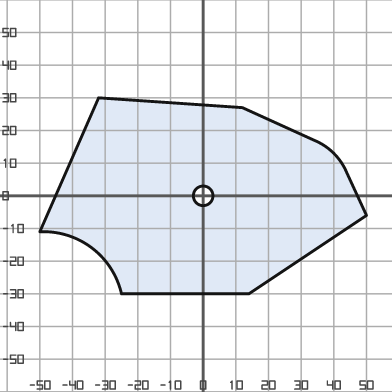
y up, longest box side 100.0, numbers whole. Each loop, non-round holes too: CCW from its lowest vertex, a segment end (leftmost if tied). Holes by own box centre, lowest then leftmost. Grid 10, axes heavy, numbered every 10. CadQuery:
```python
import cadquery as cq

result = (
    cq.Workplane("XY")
    .moveTo(-25.0, -30.0)
    .lineTo(14.0, -30.0)
    .lineTo(50.0, -6.0)
    .lineTo(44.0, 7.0)
    .threePointArc((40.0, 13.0), (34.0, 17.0))
    .lineTo(12.0, 27.0)
    .lineTo(-32.0, 30.0)
    .lineTo(-50.0, -11.0)
    .threePointArc((-34.0, -16.0), (-25.0, -30.0))
    .close()
    .moveTo(0.0, 0.0)
    .circle(3.0)
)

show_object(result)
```